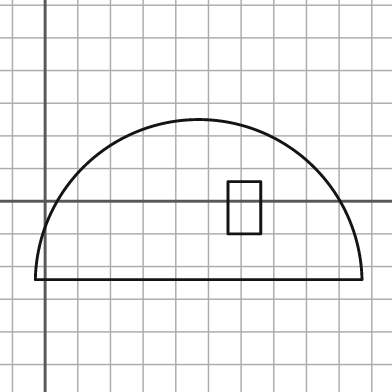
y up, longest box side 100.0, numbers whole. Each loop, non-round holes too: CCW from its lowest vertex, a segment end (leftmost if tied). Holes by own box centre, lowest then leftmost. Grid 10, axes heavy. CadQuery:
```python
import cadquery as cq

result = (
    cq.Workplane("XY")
    .moveTo(-3.0, -24.0)
    .lineTo(97.0, -24.0)
    .threePointArc((47.0, 25.0), (-3.0, -24.0))
    .close()
    .moveTo(56.0, -10.0)
    .lineTo(66.0, -10.0)
    .lineTo(66.0, 6.0)
    .lineTo(56.0, 6.0)
    .close()
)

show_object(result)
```